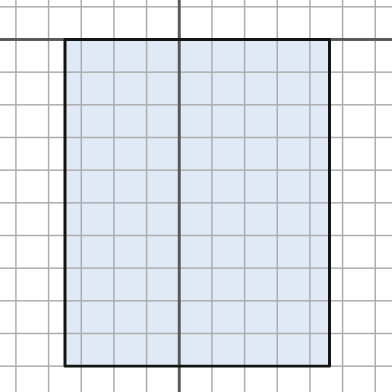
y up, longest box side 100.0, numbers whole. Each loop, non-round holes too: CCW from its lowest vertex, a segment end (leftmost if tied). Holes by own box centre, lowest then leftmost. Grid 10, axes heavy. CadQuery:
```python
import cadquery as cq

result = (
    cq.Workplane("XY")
    .moveTo(-35.0, -100.0)
    .lineTo(46.0, -100.0)
    .lineTo(46.0, 0.0)
    .lineTo(-35.0, 0.0)
    .close()
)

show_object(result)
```